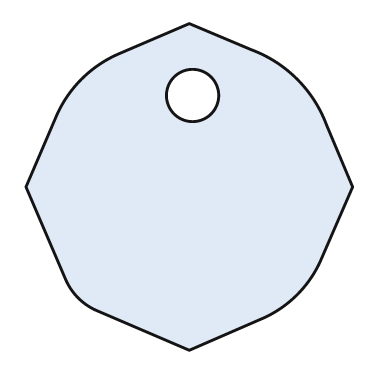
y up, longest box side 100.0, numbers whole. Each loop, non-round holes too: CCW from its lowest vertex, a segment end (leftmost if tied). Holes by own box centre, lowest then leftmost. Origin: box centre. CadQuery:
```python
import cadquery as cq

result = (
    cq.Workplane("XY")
    .moveTo(0.0, -50.0)
    .lineTo(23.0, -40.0)
    .threePointArc((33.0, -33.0), (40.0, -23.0))
    .lineTo(50.0, 0.0)
    .lineTo(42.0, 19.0)
    .threePointArc((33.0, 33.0), (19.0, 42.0))
    .lineTo(0.0, 50.0)
    .lineTo(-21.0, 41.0)
    .threePointArc((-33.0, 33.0), (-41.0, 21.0))
    .lineTo(-50.0, 0.0)
    .lineTo(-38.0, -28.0)
    .threePointArc((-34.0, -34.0), (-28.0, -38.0))
    .close()
    .moveTo(1.0, 28.0)
    .circle(8.0)
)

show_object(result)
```